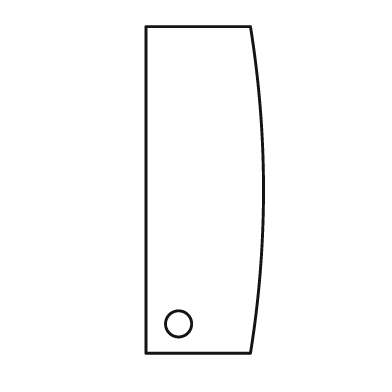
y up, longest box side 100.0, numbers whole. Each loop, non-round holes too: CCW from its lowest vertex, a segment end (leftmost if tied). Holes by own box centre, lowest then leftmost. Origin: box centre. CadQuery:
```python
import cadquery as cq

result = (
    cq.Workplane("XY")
    .moveTo(-18.0, -50.0)
    .lineTo(14.0, -50.0)
    .threePointArc((18.0, 0.0), (14.0, 50.0))
    .lineTo(-18.0, 50.0)
    .close()
    .moveTo(-8.0, -41.0)
    .circle(4.0)
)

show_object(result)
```